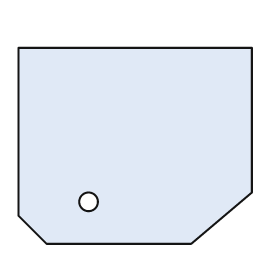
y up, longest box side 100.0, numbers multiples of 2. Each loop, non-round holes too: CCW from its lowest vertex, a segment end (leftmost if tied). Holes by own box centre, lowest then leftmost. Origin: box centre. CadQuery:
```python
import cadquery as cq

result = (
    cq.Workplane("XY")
    .moveTo(-38.0, -42.0)
    .lineTo(24.0, -42.0)
    .lineTo(50.0, -20.0)
    .lineTo(50.0, 42.0)
    .lineTo(-50.0, 42.0)
    .lineTo(-50.0, -30.0)
    .close()
    .moveTo(-20.0, -24.0)
    .circle(4.0)
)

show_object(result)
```